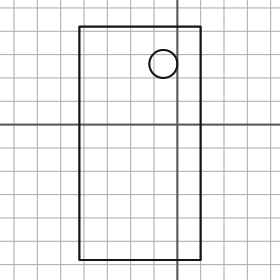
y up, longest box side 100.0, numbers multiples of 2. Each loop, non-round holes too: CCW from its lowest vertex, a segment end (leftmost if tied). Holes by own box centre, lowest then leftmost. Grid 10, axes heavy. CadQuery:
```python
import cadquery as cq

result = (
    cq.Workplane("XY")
    .moveTo(-42.0, -58.0)
    .lineTo(10.0, -58.0)
    .lineTo(10.0, 42.0)
    .lineTo(-42.0, 42.0)
    .close()
    .moveTo(-6.0, 26.0)
    .circle(6.0)
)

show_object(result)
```